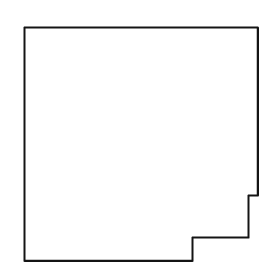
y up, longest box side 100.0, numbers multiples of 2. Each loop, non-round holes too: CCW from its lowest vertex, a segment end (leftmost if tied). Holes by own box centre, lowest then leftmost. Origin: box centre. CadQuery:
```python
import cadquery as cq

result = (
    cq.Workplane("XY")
    .moveTo(-50.0, -50.0)
    .lineTo(22.0, -50.0)
    .lineTo(22.0, -40.0)
    .lineTo(46.0, -40.0)
    .lineTo(46.0, -22.0)
    .lineTo(50.0, -22.0)
    .lineTo(50.0, 50.0)
    .lineTo(-50.0, 50.0)
    .close()
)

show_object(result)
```